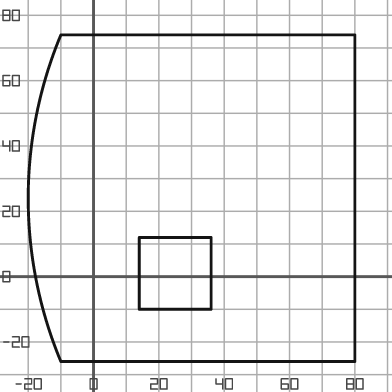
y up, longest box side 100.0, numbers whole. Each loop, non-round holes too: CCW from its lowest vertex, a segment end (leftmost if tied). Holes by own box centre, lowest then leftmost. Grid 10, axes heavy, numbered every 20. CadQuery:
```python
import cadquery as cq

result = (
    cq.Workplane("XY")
    .moveTo(-10.0, -26.0)
    .lineTo(80.0, -26.0)
    .lineTo(80.0, 74.0)
    .lineTo(-10.0, 74.0)
    .threePointArc((-20.0, 24.0), (-10.0, -26.0))
    .close()
    .moveTo(14.0, -10.0)
    .lineTo(36.0, -10.0)
    .lineTo(36.0, 12.0)
    .lineTo(14.0, 12.0)
    .close()
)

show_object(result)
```